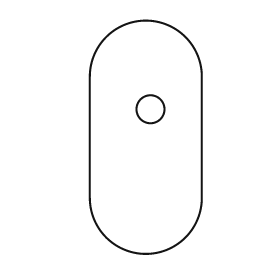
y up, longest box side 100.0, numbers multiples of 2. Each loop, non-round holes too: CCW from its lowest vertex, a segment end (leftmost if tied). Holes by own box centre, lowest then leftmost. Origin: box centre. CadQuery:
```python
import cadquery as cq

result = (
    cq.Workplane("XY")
    .moveTo(-24.0, -26.0)
    .threePointArc((0.0, -50.0), (24.0, -26.0))
    .lineTo(24.0, 26.0)
    .threePointArc((0.0, 50.0), (-24.0, 26.0))
    .close()
    .moveTo(2.0, 12.0)
    .circle(6.0)
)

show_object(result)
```